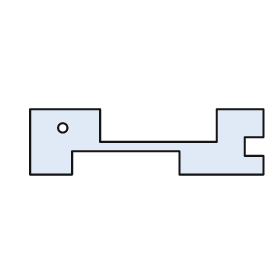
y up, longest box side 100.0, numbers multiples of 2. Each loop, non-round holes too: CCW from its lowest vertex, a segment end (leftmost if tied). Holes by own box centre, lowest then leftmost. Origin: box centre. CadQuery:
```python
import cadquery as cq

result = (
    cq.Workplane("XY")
    .moveTo(-50.0, -14.0)
    .lineTo(-32.0, -14.0)
    .lineTo(-32.0, -4.0)
    .lineTo(14.0, -4.0)
    .lineTo(14.0, -14.0)
    .lineTo(50.0, -14.0)
    .lineTo(50.0, -6.0)
    .lineTo(42.0, -6.0)
    .lineTo(42.0, 2.0)
    .lineTo(50.0, 2.0)
    .lineTo(50.0, 14.0)
    .lineTo(30.0, 14.0)
    .lineTo(30.0, 0.0)
    .lineTo(-20.0, 0.0)
    .lineTo(-20.0, 14.0)
    .lineTo(-50.0, 14.0)
    .close()
    .moveTo(-36.0, 6.0)
    .circle(2.0)
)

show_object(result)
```